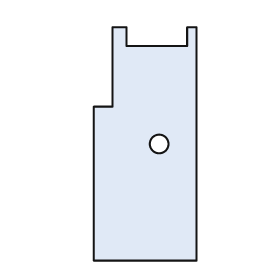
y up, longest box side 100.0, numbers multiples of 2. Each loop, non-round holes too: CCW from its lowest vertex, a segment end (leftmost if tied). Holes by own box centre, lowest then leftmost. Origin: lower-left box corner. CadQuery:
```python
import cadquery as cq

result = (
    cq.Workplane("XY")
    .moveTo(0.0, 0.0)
    .lineTo(44.0, 0.0)
    .lineTo(44.0, 100.0)
    .lineTo(40.0, 100.0)
    .lineTo(40.0, 92.0)
    .lineTo(14.0, 92.0)
    .lineTo(14.0, 100.0)
    .lineTo(8.0, 100.0)
    .lineTo(8.0, 66.0)
    .lineTo(0.0, 66.0)
    .close()
    .moveTo(28.0, 50.0)
    .circle(4.0)
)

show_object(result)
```